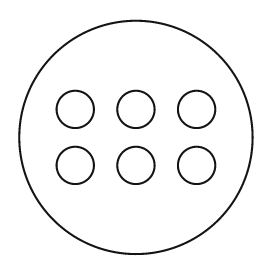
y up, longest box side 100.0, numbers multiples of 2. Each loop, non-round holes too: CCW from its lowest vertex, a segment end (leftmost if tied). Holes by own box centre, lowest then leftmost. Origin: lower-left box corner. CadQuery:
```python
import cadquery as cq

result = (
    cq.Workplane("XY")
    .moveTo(50.0, 50.0)
    .circle(50.0)
    .moveTo(24.0, 38.0)
    .circle(8.0)
    .moveTo(50.0, 38.0)
    .circle(8.0)
    .moveTo(76.0, 38.0)
    .circle(8.0)
    .moveTo(24.0, 62.0)
    .circle(8.0)
    .moveTo(50.0, 62.0)
    .circle(8.0)
    .moveTo(76.0, 62.0)
    .circle(8.0)
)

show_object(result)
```